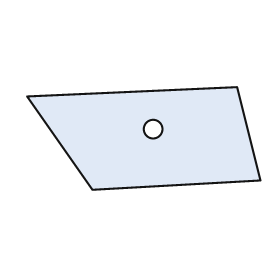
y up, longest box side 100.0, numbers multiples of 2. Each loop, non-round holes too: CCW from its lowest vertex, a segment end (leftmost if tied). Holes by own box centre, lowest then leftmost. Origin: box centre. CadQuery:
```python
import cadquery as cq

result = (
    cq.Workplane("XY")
    .moveTo(-22.0, -22.0)
    .lineTo(50.0, -18.0)
    .lineTo(40.0, 22.0)
    .lineTo(-50.0, 18.0)
    .close()
    .moveTo(4.0, 4.0)
    .circle(4.0)
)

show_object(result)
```